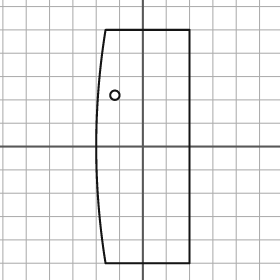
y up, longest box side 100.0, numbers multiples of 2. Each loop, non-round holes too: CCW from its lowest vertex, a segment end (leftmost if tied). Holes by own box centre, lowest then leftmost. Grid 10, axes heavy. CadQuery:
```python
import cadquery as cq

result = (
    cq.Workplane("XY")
    .moveTo(-16.0, -50.0)
    .lineTo(20.0, -50.0)
    .lineTo(20.0, 50.0)
    .lineTo(-16.0, 50.0)
    .threePointArc((-20.0, 0.0), (-16.0, -50.0))
    .close()
    .moveTo(-12.0, 22.0)
    .circle(2.0)
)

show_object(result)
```